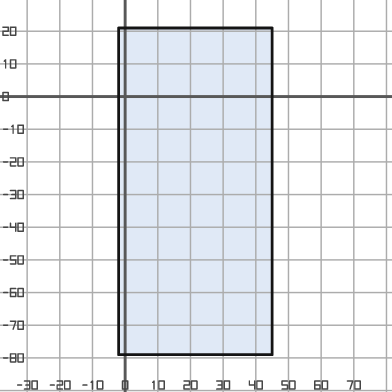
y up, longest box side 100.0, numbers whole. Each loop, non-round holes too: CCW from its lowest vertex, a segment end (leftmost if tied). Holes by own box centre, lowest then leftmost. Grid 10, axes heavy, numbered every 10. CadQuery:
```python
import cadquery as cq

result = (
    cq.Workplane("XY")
    .moveTo(-2.0, -79.0)
    .lineTo(45.0, -79.0)
    .lineTo(45.0, 21.0)
    .lineTo(-2.0, 21.0)
    .close()
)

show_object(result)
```